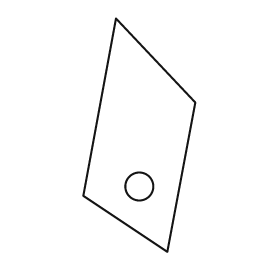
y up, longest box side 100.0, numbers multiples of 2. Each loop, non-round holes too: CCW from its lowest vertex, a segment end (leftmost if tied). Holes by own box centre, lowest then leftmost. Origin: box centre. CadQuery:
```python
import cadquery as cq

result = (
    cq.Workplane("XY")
    .moveTo(12.0, -50.0)
    .lineTo(24.0, 14.0)
    .lineTo(-10.0, 50.0)
    .lineTo(-24.0, -26.0)
    .close()
    .moveTo(0.0, -22.0)
    .circle(6.0)
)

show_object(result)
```